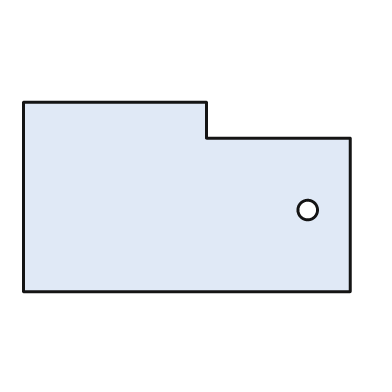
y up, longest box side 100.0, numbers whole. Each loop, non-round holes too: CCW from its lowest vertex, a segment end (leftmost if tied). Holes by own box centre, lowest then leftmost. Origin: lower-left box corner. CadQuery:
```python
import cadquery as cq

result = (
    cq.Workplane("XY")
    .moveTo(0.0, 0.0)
    .lineTo(100.0, 0.0)
    .lineTo(100.0, 47.0)
    .lineTo(56.0, 47.0)
    .lineTo(56.0, 58.0)
    .lineTo(0.0, 58.0)
    .close()
    .moveTo(87.0, 25.0)
    .circle(3.0)
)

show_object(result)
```